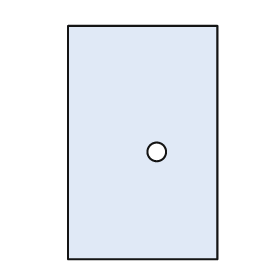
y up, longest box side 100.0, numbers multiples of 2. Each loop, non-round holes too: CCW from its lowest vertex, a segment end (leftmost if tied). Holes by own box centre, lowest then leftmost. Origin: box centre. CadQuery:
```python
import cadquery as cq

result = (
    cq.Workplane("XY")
    .moveTo(-32.0, -50.0)
    .lineTo(32.0, -50.0)
    .lineTo(32.0, 50.0)
    .lineTo(-32.0, 50.0)
    .close()
    .moveTo(6.0, -4.0)
    .circle(4.0)
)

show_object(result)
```